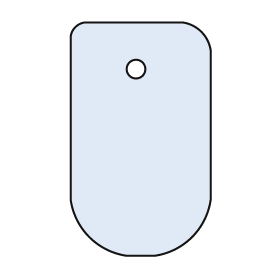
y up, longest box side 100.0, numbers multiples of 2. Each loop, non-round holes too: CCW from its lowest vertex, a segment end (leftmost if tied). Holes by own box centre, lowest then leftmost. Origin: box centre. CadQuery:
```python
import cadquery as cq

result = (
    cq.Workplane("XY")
    .moveTo(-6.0, -50.0)
    .lineTo(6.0, -50.0)
    .threePointArc((22.0, -42.0), (30.0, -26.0))
    .lineTo(30.0, 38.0)
    .threePointArc((26.0, 46.0), (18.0, 50.0))
    .lineTo(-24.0, 50.0)
    .threePointArc((-28.0, 48.0), (-30.0, 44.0))
    .lineTo(-30.0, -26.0)
    .threePointArc((-22.0, -42.0), (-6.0, -50.0))
    .close()
    .moveTo(-2.0, 30.0)
    .circle(4.0)
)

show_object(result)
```